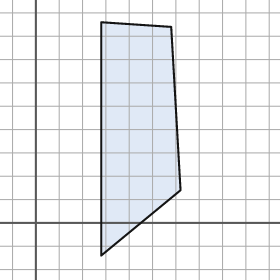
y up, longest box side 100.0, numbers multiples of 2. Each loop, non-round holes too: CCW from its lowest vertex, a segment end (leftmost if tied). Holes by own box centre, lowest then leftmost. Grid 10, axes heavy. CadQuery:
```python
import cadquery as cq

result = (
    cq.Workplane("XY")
    .moveTo(28.0, -14.0)
    .lineTo(62.0, 14.0)
    .lineTo(58.0, 84.0)
    .lineTo(28.0, 86.0)
    .close()
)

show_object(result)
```